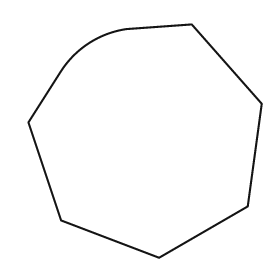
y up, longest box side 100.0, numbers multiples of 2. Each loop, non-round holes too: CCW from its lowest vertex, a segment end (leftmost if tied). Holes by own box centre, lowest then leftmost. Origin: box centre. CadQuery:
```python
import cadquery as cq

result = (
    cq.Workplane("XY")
    .moveTo(6.0, -50.0)
    .lineTo(44.0, -28.0)
    .lineTo(50.0, 16.0)
    .lineTo(20.0, 50.0)
    .lineTo(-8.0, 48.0)
    .threePointArc((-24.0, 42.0), (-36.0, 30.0))
    .lineTo(-50.0, 8.0)
    .lineTo(-36.0, -34.0)
    .close()
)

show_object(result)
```